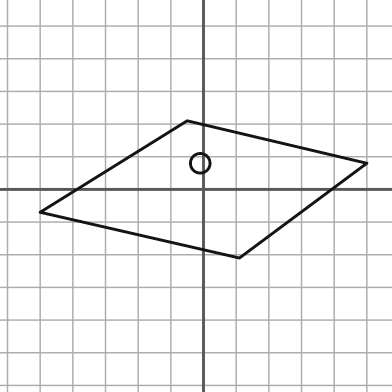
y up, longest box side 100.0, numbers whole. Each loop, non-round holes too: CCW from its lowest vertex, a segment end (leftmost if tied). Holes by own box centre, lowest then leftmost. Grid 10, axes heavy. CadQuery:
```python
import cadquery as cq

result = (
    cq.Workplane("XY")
    .moveTo(11.0, -21.0)
    .lineTo(50.0, 8.0)
    .lineTo(-5.0, 21.0)
    .lineTo(-50.0, -7.0)
    .close()
    .moveTo(-1.0, 8.0)
    .circle(3.0)
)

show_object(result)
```